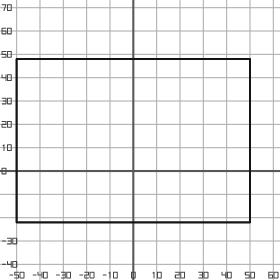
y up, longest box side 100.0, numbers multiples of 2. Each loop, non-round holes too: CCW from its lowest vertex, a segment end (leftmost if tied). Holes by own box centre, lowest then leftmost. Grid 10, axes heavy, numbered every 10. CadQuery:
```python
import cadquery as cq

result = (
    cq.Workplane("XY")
    .moveTo(-50.0, -22.0)
    .lineTo(50.0, -22.0)
    .lineTo(50.0, 48.0)
    .lineTo(-50.0, 48.0)
    .close()
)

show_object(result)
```